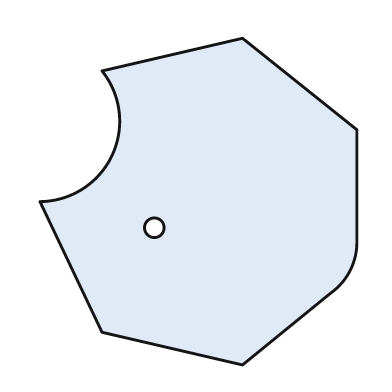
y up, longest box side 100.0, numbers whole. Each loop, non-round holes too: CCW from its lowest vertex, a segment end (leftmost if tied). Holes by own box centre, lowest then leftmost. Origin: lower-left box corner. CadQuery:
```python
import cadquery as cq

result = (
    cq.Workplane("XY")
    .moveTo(62.0, 0.0)
    .lineTo(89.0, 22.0)
    .threePointArc((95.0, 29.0), (97.0, 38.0))
    .lineTo(97.0, 72.0)
    .lineTo(62.0, 100.0)
    .lineTo(19.0, 90.0)
    .threePointArc((22.0, 64.0), (0.0, 50.0))
    .lineTo(19.0, 10.0)
    .close()
    .moveTo(35.0, 42.0)
    .circle(3.0)
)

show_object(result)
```